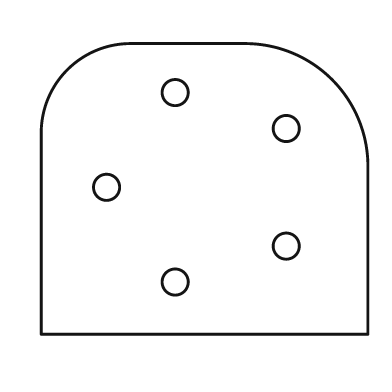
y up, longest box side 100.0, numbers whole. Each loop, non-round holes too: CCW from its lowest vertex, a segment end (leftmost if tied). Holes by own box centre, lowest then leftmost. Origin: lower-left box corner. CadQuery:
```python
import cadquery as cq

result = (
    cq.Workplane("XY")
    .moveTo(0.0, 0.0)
    .lineTo(100.0, 0.0)
    .lineTo(100.0, 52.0)
    .threePointArc((89.0, 78.0), (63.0, 89.0))
    .lineTo(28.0, 89.0)
    .threePointArc((8.0, 81.0), (0.0, 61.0))
    .close()
    .moveTo(41.0, 16.0)
    .circle(4.0)
    .moveTo(75.0, 27.0)
    .circle(4.0)
    .moveTo(20.0, 45.0)
    .circle(4.0)
    .moveTo(75.0, 63.0)
    .circle(4.0)
    .moveTo(41.0, 74.0)
    .circle(4.0)
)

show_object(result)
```